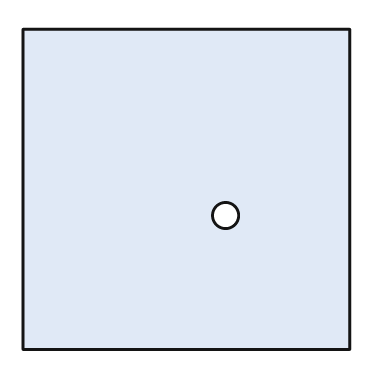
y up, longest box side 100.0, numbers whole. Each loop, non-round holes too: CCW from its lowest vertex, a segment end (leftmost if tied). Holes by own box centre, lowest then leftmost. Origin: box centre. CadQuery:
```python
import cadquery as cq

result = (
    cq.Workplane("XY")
    .moveTo(-50.0, -49.0)
    .lineTo(50.0, -49.0)
    .lineTo(50.0, 49.0)
    .lineTo(-50.0, 49.0)
    .close()
    .moveTo(12.0, -8.0)
    .circle(4.0)
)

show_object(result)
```